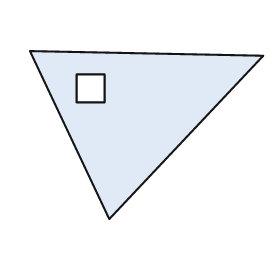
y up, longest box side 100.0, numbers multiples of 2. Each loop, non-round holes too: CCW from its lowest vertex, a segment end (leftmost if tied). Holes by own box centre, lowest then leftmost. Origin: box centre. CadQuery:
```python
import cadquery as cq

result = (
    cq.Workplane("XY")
    .moveTo(-16.0, -36.0)
    .lineTo(50.0, 34.0)
    .lineTo(-50.0, 36.0)
    .close()
    .moveTo(-30.0, 14.0)
    .lineTo(-18.0, 14.0)
    .lineTo(-18.0, 26.0)
    .lineTo(-30.0, 26.0)
    .close()
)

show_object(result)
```